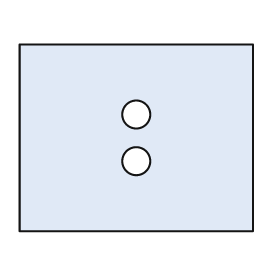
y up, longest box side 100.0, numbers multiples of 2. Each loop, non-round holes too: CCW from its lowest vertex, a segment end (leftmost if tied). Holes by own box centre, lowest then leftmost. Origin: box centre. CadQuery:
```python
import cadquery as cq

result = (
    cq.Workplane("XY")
    .moveTo(-50.0, -40.0)
    .lineTo(50.0, -40.0)
    .lineTo(50.0, 40.0)
    .lineTo(-50.0, 40.0)
    .close()
    .moveTo(0.0, -10.0)
    .circle(6.0)
    .moveTo(0.0, 10.0)
    .circle(6.0)
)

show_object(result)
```